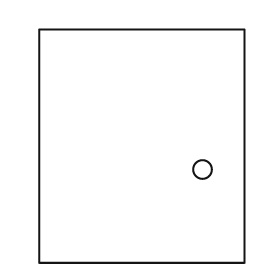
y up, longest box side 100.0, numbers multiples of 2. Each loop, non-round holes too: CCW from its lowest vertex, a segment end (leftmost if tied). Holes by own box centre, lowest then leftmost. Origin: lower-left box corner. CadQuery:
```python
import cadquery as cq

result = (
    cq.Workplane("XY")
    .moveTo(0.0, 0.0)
    .lineTo(88.0, 0.0)
    .lineTo(88.0, 100.0)
    .lineTo(0.0, 100.0)
    .close()
    .moveTo(70.0, 40.0)
    .circle(4.0)
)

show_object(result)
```